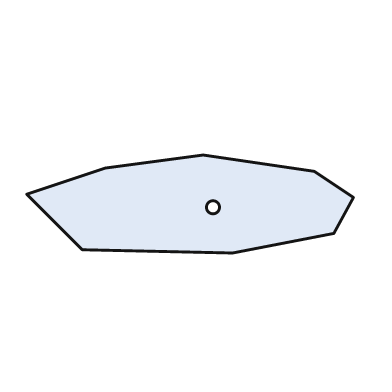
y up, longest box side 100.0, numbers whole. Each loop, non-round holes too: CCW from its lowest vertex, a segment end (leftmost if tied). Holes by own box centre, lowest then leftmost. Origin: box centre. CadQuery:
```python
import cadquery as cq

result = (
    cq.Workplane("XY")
    .moveTo(13.0, -15.0)
    .lineTo(44.0, -9.0)
    .lineTo(50.0, 2.0)
    .lineTo(38.0, 10.0)
    .lineTo(4.0, 15.0)
    .lineTo(-26.0, 11.0)
    .lineTo(-50.0, 3.0)
    .lineTo(-33.0, -14.0)
    .close()
    .moveTo(7.0, -1.0)
    .circle(2.0)
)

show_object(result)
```